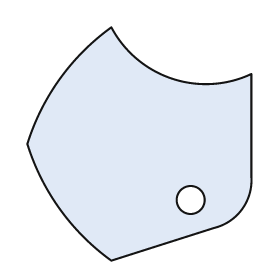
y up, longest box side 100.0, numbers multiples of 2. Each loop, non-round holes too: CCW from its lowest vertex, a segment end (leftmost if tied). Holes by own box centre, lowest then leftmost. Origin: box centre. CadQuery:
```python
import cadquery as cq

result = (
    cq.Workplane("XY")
    .moveTo(-12.0, -50.0)
    .lineTo(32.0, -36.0)
    .threePointArc((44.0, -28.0), (48.0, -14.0))
    .lineTo(48.0, 30.0)
    .threePointArc((14.0, 28.0), (-12.0, 50.0))
    .threePointArc((-34.0, 28.0), (-48.0, 0.0))
    .threePointArc((-34.0, -28.0), (-12.0, -50.0))
    .close()
    .moveTo(22.0, -24.0)
    .circle(6.0)
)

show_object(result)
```